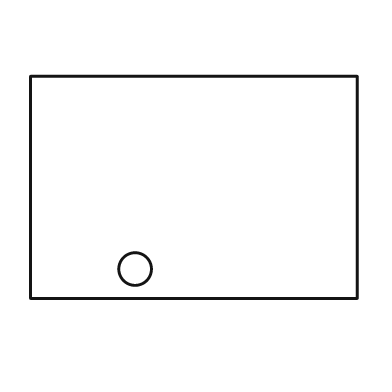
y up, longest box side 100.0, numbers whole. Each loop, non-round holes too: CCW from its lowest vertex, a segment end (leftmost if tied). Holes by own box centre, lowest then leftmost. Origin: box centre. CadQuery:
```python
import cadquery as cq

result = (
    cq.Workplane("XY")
    .moveTo(-50.0, -34.0)
    .lineTo(50.0, -34.0)
    .lineTo(50.0, 34.0)
    .lineTo(-50.0, 34.0)
    .close()
    .moveTo(-18.0, -25.0)
    .circle(5.0)
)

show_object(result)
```